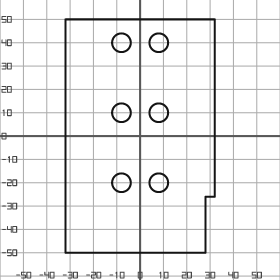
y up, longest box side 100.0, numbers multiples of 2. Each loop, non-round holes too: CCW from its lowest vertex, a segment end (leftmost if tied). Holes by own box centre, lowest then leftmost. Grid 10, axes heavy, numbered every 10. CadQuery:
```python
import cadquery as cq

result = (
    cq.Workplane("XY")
    .moveTo(-32.0, -50.0)
    .lineTo(28.0, -50.0)
    .lineTo(28.0, -26.0)
    .lineTo(32.0, -26.0)
    .lineTo(32.0, 50.0)
    .lineTo(-32.0, 50.0)
    .close()
    .moveTo(-8.0, -20.0)
    .circle(4.0)
    .moveTo(8.0, -20.0)
    .circle(4.0)
    .moveTo(-8.0, 10.0)
    .circle(4.0)
    .moveTo(8.0, 10.0)
    .circle(4.0)
    .moveTo(-8.0, 40.0)
    .circle(4.0)
    .moveTo(8.0, 40.0)
    .circle(4.0)
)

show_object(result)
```